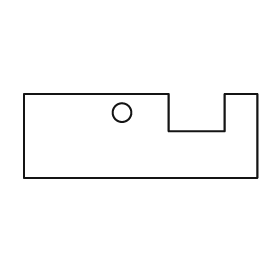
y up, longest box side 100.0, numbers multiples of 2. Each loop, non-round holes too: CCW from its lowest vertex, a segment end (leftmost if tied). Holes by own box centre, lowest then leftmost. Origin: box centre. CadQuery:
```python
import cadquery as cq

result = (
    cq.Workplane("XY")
    .moveTo(-50.0, -18.0)
    .lineTo(50.0, -18.0)
    .lineTo(50.0, 18.0)
    .lineTo(36.0, 18.0)
    .lineTo(36.0, 2.0)
    .lineTo(12.0, 2.0)
    .lineTo(12.0, 18.0)
    .lineTo(-50.0, 18.0)
    .close()
    .moveTo(-8.0, 10.0)
    .circle(4.0)
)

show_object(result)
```